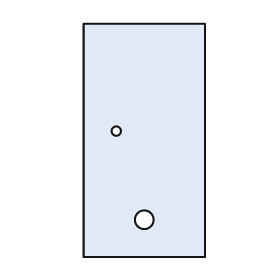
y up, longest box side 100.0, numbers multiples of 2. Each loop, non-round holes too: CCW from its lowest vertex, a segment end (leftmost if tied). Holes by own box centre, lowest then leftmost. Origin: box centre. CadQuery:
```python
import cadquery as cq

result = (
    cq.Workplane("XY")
    .moveTo(-26.0, -50.0)
    .lineTo(26.0, -50.0)
    .lineTo(26.0, 50.0)
    .lineTo(-26.0, 50.0)
    .close()
    .moveTo(0.0, -34.0)
    .circle(4.0)
    .moveTo(-12.0, 4.0)
    .circle(2.0)
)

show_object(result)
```